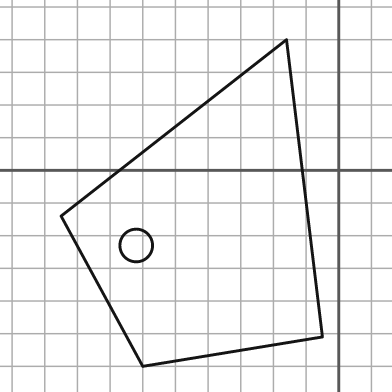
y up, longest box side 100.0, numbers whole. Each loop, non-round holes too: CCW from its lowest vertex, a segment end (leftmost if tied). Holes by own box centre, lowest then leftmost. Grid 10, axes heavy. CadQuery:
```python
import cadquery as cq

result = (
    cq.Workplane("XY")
    .moveTo(-60.0, -60.0)
    .lineTo(-5.0, -51.0)
    .lineTo(-16.0, 40.0)
    .lineTo(-85.0, -14.0)
    .close()
    .moveTo(-62.0, -23.0)
    .circle(5.0)
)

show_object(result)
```